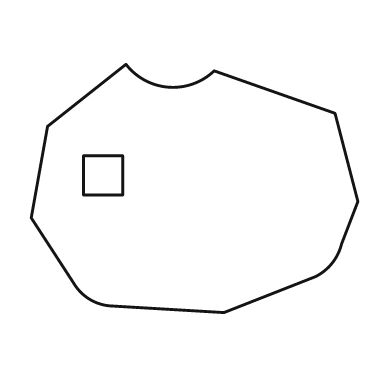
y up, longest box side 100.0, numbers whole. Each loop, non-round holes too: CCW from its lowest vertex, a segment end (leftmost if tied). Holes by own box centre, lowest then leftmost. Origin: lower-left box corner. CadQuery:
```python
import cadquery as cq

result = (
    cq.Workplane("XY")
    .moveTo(59.0, 0.0)
    .lineTo(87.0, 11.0)
    .threePointArc((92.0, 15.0), (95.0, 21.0))
    .lineTo(100.0, 34.0)
    .lineTo(93.0, 61.0)
    .lineTo(56.0, 74.0)
    .threePointArc((42.0, 69.0), (29.0, 76.0))
    .lineTo(5.0, 57.0)
    .lineTo(0.0, 29.0)
    .lineTo(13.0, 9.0)
    .threePointArc((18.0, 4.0), (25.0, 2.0))
    .close()
    .moveTo(16.0, 36.0)
    .lineTo(28.0, 36.0)
    .lineTo(28.0, 48.0)
    .lineTo(16.0, 48.0)
    .close()
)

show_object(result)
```